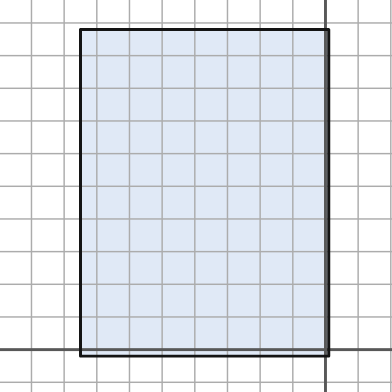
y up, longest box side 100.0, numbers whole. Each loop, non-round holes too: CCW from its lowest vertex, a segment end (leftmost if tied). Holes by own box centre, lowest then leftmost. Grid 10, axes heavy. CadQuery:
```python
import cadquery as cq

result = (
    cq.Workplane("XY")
    .moveTo(-75.0, -2.0)
    .lineTo(1.0, -2.0)
    .lineTo(1.0, 98.0)
    .lineTo(-75.0, 98.0)
    .close()
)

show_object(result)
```